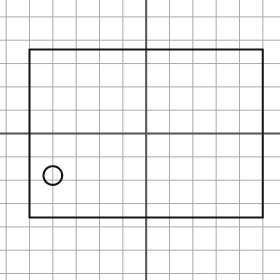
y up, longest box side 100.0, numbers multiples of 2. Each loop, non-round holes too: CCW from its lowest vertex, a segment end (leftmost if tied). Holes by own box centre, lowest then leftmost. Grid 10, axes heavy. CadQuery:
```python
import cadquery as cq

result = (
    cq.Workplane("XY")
    .moveTo(-50.0, -36.0)
    .lineTo(50.0, -36.0)
    .lineTo(50.0, 36.0)
    .lineTo(-50.0, 36.0)
    .close()
    .moveTo(-40.0, -18.0)
    .circle(4.0)
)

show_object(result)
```